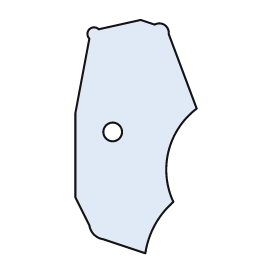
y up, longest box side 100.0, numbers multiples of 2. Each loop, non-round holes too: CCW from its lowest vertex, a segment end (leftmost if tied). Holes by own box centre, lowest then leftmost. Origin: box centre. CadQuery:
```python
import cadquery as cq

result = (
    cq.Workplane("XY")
    .moveTo(4.0, -50.0)
    .threePointArc((8.0, -38.0), (16.0, -28.0))
    .threePointArc((14.0, -6.0), (26.0, 12.0))
    .lineTo(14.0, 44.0)
    .threePointArc((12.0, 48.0), (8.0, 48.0))
    .lineTo(2.0, 50.0)
    .lineTo(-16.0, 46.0)
    .threePointArc((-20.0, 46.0), (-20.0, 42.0))
    .lineTo(-26.0, 10.0)
    .lineTo(-26.0, -26.0)
    .lineTo(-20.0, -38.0)
    .threePointArc((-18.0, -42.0), (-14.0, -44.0))
    .close()
    .moveTo(-10.0, 2.0)
    .circle(4.0)
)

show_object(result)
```